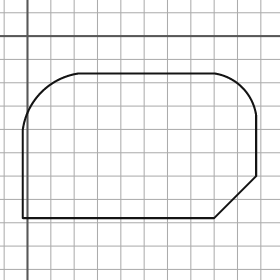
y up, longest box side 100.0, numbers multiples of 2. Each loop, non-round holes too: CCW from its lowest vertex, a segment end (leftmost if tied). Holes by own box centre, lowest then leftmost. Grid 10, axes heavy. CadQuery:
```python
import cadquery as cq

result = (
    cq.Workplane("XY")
    .moveTo(-2.0, -78.0)
    .lineTo(80.0, -78.0)
    .lineTo(98.0, -60.0)
    .lineTo(98.0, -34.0)
    .threePointArc((92.0, -22.0), (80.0, -16.0))
    .lineTo(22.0, -16.0)
    .threePointArc((6.0, -24.0), (-2.0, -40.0))
    .close()
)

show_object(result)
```